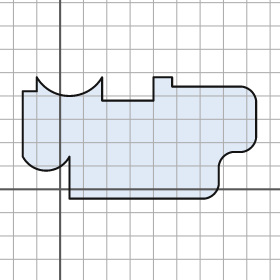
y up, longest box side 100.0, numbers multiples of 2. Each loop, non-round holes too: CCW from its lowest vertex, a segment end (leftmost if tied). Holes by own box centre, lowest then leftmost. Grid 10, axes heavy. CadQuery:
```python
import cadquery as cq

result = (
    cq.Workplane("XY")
    .moveTo(4.0, -4.0)
    .lineTo(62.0, -4.0)
    .threePointArc((66.0, -2.0), (68.0, 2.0))
    .lineTo(68.0, 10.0)
    .threePointArc((70.0, 14.0), (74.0, 16.0))
    .lineTo(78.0, 16.0)
    .threePointArc((82.0, 18.0), (84.0, 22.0))
    .lineTo(84.0, 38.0)
    .threePointArc((82.0, 42.0), (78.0, 44.0))
    .lineTo(48.0, 44.0)
    .lineTo(48.0, 48.0)
    .lineTo(40.0, 48.0)
    .lineTo(40.0, 38.0)
    .lineTo(18.0, 38.0)
    .lineTo(18.0, 48.0)
    .threePointArc((4.0, 40.0), (-10.0, 48.0))
    .lineTo(-10.0, 42.0)
    .lineTo(-16.0, 42.0)
    .lineTo(-16.0, 14.0)
    .threePointArc((-6.0, 8.0), (4.0, 14.0))
    .close()
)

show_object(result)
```